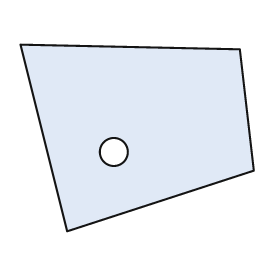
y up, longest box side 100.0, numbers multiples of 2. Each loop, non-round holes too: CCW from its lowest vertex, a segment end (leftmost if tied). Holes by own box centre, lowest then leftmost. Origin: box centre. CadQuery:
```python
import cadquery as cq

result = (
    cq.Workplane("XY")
    .moveTo(-30.0, -40.0)
    .lineTo(50.0, -14.0)
    .lineTo(44.0, 38.0)
    .lineTo(-50.0, 40.0)
    .close()
    .moveTo(-10.0, -6.0)
    .circle(6.0)
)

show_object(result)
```